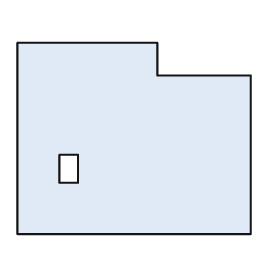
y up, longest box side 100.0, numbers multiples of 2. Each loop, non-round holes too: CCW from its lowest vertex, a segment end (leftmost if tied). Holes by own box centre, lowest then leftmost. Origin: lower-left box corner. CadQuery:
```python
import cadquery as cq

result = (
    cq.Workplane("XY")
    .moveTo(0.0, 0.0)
    .lineTo(100.0, 0.0)
    .lineTo(100.0, 68.0)
    .lineTo(60.0, 68.0)
    .lineTo(60.0, 82.0)
    .lineTo(0.0, 82.0)
    .close()
    .moveTo(18.0, 22.0)
    .lineTo(26.0, 22.0)
    .lineTo(26.0, 34.0)
    .lineTo(18.0, 34.0)
    .close()
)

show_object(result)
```